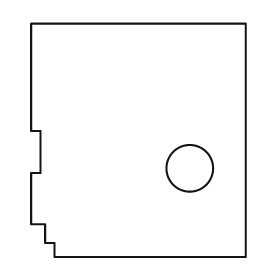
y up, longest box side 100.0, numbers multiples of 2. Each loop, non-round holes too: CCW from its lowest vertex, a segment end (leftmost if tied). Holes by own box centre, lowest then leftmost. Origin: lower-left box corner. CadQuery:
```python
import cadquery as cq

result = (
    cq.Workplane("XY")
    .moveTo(10.0, 0.0)
    .lineTo(92.0, 0.0)
    .lineTo(92.0, 100.0)
    .lineTo(0.0, 100.0)
    .lineTo(0.0, 54.0)
    .lineTo(4.0, 54.0)
    .lineTo(4.0, 36.0)
    .lineTo(0.0, 36.0)
    .lineTo(0.0, 14.0)
    .lineTo(6.0, 14.0)
    .lineTo(6.0, 6.0)
    .lineTo(10.0, 6.0)
    .close()
    .moveTo(68.0, 38.0)
    .circle(10.0)
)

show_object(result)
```